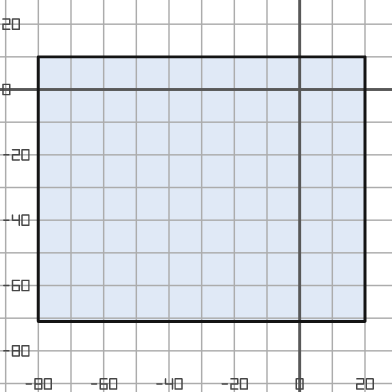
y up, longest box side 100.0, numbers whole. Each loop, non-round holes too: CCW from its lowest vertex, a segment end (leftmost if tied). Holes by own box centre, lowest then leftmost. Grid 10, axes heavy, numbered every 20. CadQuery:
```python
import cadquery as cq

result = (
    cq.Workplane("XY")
    .moveTo(-80.0, -71.0)
    .lineTo(20.0, -71.0)
    .lineTo(20.0, 10.0)
    .lineTo(-80.0, 10.0)
    .close()
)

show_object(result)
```